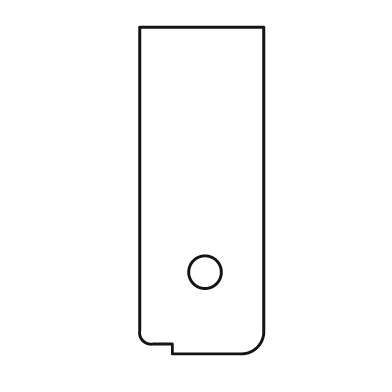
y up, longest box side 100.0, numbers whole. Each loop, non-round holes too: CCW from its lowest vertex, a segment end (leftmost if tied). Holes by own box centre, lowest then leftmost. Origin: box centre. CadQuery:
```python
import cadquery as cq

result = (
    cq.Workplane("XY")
    .moveTo(-9.0, -50.0)
    .lineTo(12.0, -50.0)
    .threePointArc((17.0, -48.0), (19.0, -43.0))
    .lineTo(19.0, 50.0)
    .lineTo(-19.0, 50.0)
    .lineTo(-19.0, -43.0)
    .threePointArc((-18.0, -46.0), (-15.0, -47.0))
    .lineTo(-9.0, -47.0)
    .close()
    .moveTo(1.0, -25.0)
    .circle(5.0)
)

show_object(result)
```